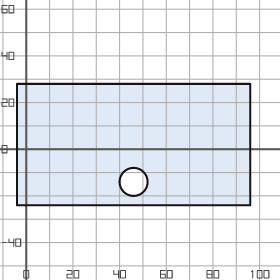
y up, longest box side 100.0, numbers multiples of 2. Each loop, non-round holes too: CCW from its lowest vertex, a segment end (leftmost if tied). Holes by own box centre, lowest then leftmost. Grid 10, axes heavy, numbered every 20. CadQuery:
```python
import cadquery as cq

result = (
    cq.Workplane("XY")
    .moveTo(-4.0, -24.0)
    .lineTo(96.0, -24.0)
    .lineTo(96.0, 28.0)
    .lineTo(-4.0, 28.0)
    .close()
    .moveTo(46.0, -14.0)
    .circle(6.0)
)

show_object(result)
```